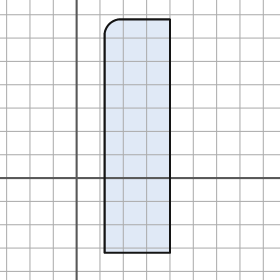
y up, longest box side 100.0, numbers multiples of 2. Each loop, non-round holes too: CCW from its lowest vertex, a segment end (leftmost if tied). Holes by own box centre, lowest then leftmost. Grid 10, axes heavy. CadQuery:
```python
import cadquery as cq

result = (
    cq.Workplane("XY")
    .moveTo(12.0, -32.0)
    .lineTo(40.0, -32.0)
    .lineTo(40.0, 68.0)
    .lineTo(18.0, 68.0)
    .threePointArc((14.0, 66.0), (12.0, 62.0))
    .close()
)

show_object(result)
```